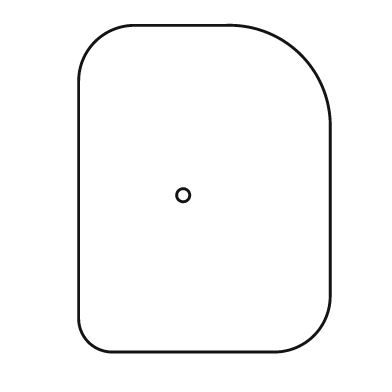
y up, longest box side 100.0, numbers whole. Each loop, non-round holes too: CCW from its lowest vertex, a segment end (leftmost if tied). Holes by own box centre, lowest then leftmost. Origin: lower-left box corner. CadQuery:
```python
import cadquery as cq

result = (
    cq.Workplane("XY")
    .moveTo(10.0, 0.0)
    .lineTo(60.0, 0.0)
    .threePointArc((72.0, 5.0), (77.0, 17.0))
    .lineTo(77.0, 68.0)
    .threePointArc((68.0, 91.0), (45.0, 100.0))
    .lineTo(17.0, 100.0)
    .threePointArc((5.0, 95.0), (0.0, 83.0))
    .lineTo(0.0, 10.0)
    .threePointArc((3.0, 3.0), (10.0, 0.0))
    .close()
    .moveTo(32.0, 48.0)
    .circle(2.0)
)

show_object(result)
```